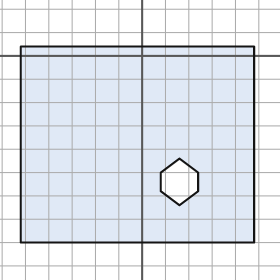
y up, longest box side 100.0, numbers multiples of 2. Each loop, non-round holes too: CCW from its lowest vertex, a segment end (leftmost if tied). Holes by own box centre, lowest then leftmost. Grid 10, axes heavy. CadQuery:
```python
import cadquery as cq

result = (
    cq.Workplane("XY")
    .moveTo(-52.0, -80.0)
    .lineTo(48.0, -80.0)
    .lineTo(48.0, 4.0)
    .lineTo(-52.0, 4.0)
    .close()
    .moveTo(16.0, -64.0)
    .lineTo(24.0, -58.0)
    .lineTo(24.0, -50.0)
    .lineTo(16.0, -44.0)
    .lineTo(8.0, -50.0)
    .lineTo(8.0, -58.0)
    .close()
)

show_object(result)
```